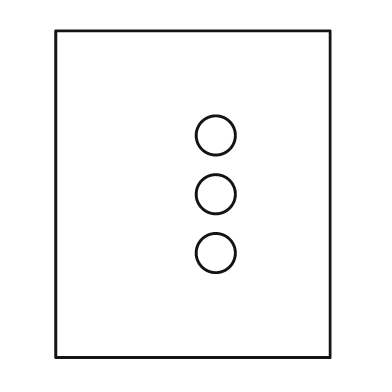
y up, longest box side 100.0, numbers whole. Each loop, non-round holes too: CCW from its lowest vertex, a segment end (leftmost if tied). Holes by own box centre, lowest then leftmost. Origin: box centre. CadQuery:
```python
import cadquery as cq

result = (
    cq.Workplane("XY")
    .moveTo(-42.0, -50.0)
    .lineTo(42.0, -50.0)
    .lineTo(42.0, 50.0)
    .lineTo(-42.0, 50.0)
    .close()
    .moveTo(7.0, -18.0)
    .circle(6.0)
    .moveTo(7.0, 0.0)
    .circle(6.0)
    .moveTo(7.0, 18.0)
    .circle(6.0)
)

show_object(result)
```